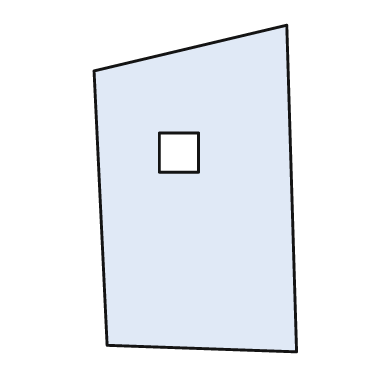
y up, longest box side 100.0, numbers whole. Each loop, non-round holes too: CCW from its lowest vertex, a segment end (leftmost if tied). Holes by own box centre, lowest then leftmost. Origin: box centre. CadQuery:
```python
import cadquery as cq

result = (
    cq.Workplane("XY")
    .moveTo(31.0, -50.0)
    .lineTo(28.0, 50.0)
    .lineTo(-31.0, 36.0)
    .lineTo(-27.0, -48.0)
    .close()
    .moveTo(-11.0, 5.0)
    .lineTo(1.0, 5.0)
    .lineTo(1.0, 17.0)
    .lineTo(-11.0, 17.0)
    .close()
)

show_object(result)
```